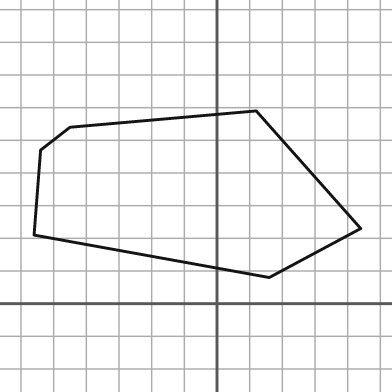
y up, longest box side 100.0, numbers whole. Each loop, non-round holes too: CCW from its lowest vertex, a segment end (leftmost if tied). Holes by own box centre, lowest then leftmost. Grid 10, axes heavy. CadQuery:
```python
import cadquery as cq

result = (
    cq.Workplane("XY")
    .moveTo(16.0, 8.0)
    .lineTo(44.0, 23.0)
    .lineTo(12.0, 59.0)
    .lineTo(-45.0, 54.0)
    .lineTo(-54.0, 47.0)
    .lineTo(-56.0, 21.0)
    .close()
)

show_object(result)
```